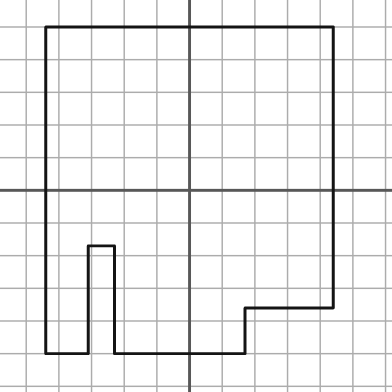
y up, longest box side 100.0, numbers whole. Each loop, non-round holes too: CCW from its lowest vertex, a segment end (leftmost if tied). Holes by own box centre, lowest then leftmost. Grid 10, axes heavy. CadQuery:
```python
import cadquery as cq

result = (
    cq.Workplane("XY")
    .moveTo(-44.0, -50.0)
    .lineTo(-31.0, -50.0)
    .lineTo(-31.0, -17.0)
    .lineTo(-23.0, -17.0)
    .lineTo(-23.0, -50.0)
    .lineTo(17.0, -50.0)
    .lineTo(17.0, -36.0)
    .lineTo(44.0, -36.0)
    .lineTo(44.0, 50.0)
    .lineTo(-44.0, 50.0)
    .close()
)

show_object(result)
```